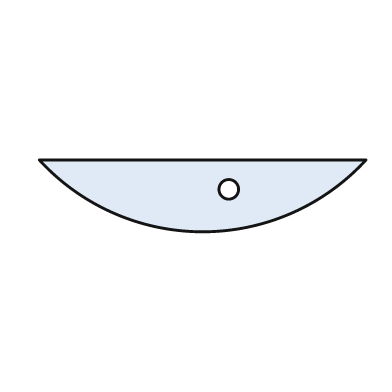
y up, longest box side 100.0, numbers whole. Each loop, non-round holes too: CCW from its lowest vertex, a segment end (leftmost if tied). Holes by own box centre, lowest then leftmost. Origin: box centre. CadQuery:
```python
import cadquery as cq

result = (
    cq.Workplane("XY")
    .moveTo(-50.0, 11.0)
    .threePointArc((0.0, -11.0), (50.0, 11.0))
    .close()
    .moveTo(8.0, 2.0)
    .circle(3.0)
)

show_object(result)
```